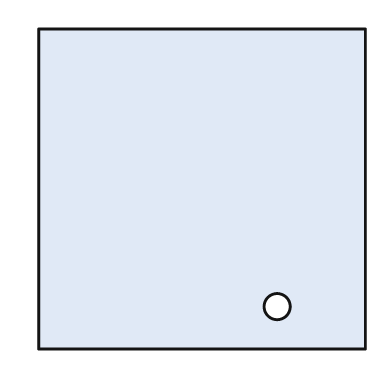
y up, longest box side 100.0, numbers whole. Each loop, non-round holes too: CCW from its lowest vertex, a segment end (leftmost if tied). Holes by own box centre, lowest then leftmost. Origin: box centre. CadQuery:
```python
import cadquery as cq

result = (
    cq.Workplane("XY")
    .moveTo(-50.0, -49.0)
    .lineTo(50.0, -49.0)
    .lineTo(50.0, 49.0)
    .lineTo(-50.0, 49.0)
    .close()
    .moveTo(23.0, -36.0)
    .circle(4.0)
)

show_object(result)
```